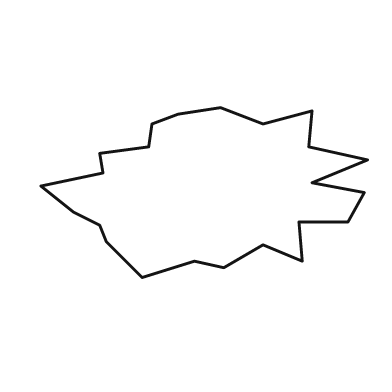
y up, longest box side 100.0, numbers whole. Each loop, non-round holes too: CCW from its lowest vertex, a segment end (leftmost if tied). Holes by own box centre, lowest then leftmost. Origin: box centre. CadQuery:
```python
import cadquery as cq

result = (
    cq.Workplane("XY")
    .moveTo(-19.0, -26.0)
    .lineTo(-3.0, -21.0)
    .lineTo(6.0, -23.0)
    .lineTo(18.0, -16.0)
    .lineTo(30.0, -21.0)
    .lineTo(29.0, -9.0)
    .lineTo(44.0, -9.0)
    .lineTo(49.0, 0.0)
    .lineTo(33.0, 3.0)
    .lineTo(50.0, 10.0)
    .lineTo(32.0, 14.0)
    .lineTo(33.0, 25.0)
    .lineTo(18.0, 21.0)
    .lineTo(5.0, 26.0)
    .lineTo(-8.0, 24.0)
    .lineTo(-16.0, 21.0)
    .lineTo(-17.0, 14.0)
    .lineTo(-32.0, 12.0)
    .lineTo(-31.0, 6.0)
    .lineTo(-50.0, 2.0)
    .lineTo(-40.0, -6.0)
    .lineTo(-32.0, -10.0)
    .lineTo(-30.0, -15.0)
    .close()
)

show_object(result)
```